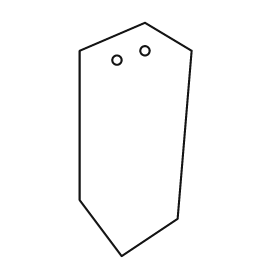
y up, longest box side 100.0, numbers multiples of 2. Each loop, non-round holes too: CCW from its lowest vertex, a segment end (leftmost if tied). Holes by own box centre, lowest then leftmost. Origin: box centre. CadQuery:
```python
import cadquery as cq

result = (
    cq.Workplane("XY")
    .moveTo(-6.0, -50.0)
    .lineTo(18.0, -34.0)
    .lineTo(24.0, 38.0)
    .lineTo(4.0, 50.0)
    .lineTo(-24.0, 38.0)
    .lineTo(-24.0, -26.0)
    .close()
    .moveTo(-8.0, 34.0)
    .circle(2.0)
    .moveTo(4.0, 38.0)
    .circle(2.0)
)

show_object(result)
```